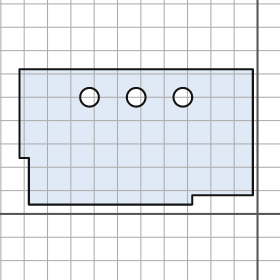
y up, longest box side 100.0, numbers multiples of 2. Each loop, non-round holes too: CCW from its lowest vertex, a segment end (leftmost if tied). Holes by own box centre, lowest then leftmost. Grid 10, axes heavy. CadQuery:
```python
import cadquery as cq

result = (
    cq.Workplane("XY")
    .moveTo(-98.0, 4.0)
    .lineTo(-28.0, 4.0)
    .lineTo(-28.0, 8.0)
    .lineTo(-2.0, 8.0)
    .lineTo(-2.0, 62.0)
    .lineTo(-102.0, 62.0)
    .lineTo(-102.0, 24.0)
    .lineTo(-98.0, 24.0)
    .close()
    .moveTo(-72.0, 50.0)
    .circle(4.0)
    .moveTo(-52.0, 50.0)
    .circle(4.0)
    .moveTo(-32.0, 50.0)
    .circle(4.0)
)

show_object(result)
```